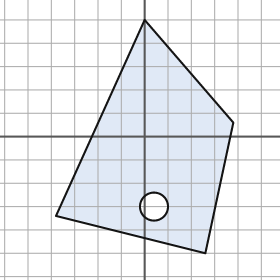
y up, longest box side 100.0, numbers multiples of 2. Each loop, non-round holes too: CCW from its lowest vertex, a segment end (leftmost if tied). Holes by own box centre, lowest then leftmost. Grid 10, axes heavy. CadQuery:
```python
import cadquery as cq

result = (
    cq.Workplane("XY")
    .moveTo(26.0, -50.0)
    .lineTo(38.0, 6.0)
    .lineTo(0.0, 50.0)
    .lineTo(-38.0, -34.0)
    .close()
    .moveTo(4.0, -30.0)
    .circle(6.0)
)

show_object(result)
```